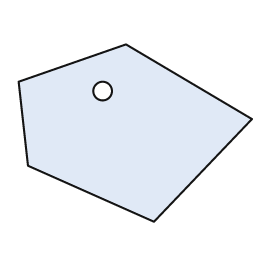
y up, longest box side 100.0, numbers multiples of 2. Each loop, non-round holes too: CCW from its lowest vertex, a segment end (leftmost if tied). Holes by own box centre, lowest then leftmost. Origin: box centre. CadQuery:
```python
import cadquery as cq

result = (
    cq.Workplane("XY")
    .moveTo(8.0, -38.0)
    .lineTo(50.0, 6.0)
    .lineTo(-4.0, 38.0)
    .lineTo(-50.0, 22.0)
    .lineTo(-46.0, -14.0)
    .close()
    .moveTo(-14.0, 18.0)
    .circle(4.0)
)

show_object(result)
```